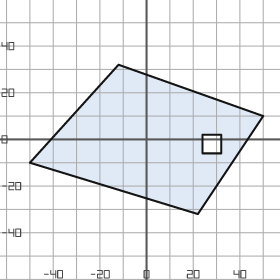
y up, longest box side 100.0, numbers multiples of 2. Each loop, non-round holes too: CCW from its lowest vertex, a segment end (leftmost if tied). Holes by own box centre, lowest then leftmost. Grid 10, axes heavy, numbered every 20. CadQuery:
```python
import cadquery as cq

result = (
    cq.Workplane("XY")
    .moveTo(22.0, -32.0)
    .lineTo(50.0, 10.0)
    .lineTo(-12.0, 32.0)
    .lineTo(-50.0, -10.0)
    .close()
    .moveTo(24.0, -6.0)
    .lineTo(32.0, -6.0)
    .lineTo(32.0, 2.0)
    .lineTo(24.0, 2.0)
    .close()
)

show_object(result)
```